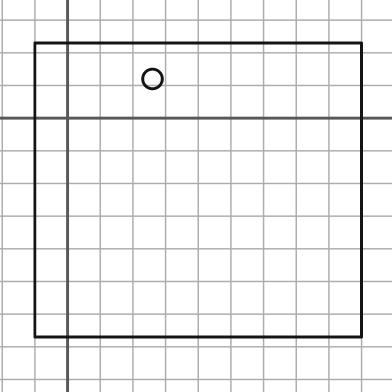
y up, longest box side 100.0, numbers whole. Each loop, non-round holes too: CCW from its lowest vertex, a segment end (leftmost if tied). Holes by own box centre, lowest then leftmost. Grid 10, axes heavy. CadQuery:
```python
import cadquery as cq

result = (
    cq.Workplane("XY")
    .moveTo(-10.0, -67.0)
    .lineTo(90.0, -67.0)
    .lineTo(90.0, 23.0)
    .lineTo(-10.0, 23.0)
    .close()
    .moveTo(26.0, 12.0)
    .circle(3.0)
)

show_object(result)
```